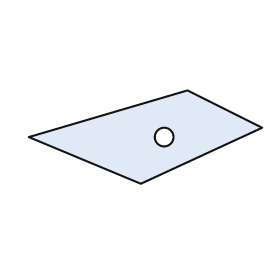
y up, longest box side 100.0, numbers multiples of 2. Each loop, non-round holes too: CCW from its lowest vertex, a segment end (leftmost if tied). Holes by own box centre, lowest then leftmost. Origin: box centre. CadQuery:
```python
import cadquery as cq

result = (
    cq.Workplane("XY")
    .moveTo(-2.0, -20.0)
    .lineTo(50.0, 4.0)
    .lineTo(18.0, 20.0)
    .lineTo(-50.0, 0.0)
    .close()
    .moveTo(8.0, 0.0)
    .circle(4.0)
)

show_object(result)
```